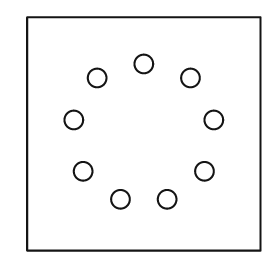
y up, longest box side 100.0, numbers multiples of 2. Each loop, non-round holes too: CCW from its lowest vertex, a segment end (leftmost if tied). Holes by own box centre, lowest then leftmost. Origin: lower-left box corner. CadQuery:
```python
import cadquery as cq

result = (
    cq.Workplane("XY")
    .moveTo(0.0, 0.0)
    .lineTo(100.0, 0.0)
    .lineTo(100.0, 100.0)
    .lineTo(0.0, 100.0)
    .close()
    .moveTo(40.0, 22.0)
    .circle(4.0)
    .moveTo(60.0, 22.0)
    .circle(4.0)
    .moveTo(24.0, 34.0)
    .circle(4.0)
    .moveTo(76.0, 34.0)
    .circle(4.0)
    .moveTo(20.0, 56.0)
    .circle(4.0)
    .moveTo(80.0, 56.0)
    .circle(4.0)
    .moveTo(30.0, 74.0)
    .circle(4.0)
    .moveTo(70.0, 74.0)
    .circle(4.0)
    .moveTo(50.0, 80.0)
    .circle(4.0)
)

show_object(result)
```